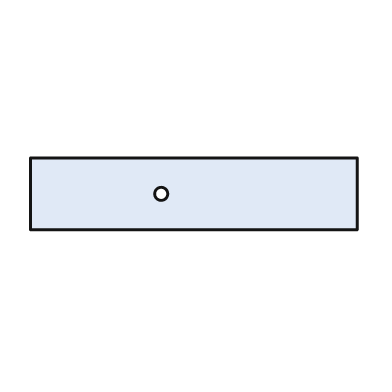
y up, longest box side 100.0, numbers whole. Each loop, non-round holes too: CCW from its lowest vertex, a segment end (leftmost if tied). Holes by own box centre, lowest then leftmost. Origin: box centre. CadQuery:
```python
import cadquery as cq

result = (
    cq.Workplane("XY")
    .moveTo(-50.0, -11.0)
    .lineTo(50.0, -11.0)
    .lineTo(50.0, 11.0)
    .lineTo(-50.0, 11.0)
    .close()
    .moveTo(-10.0, 0.0)
    .circle(2.0)
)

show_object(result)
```